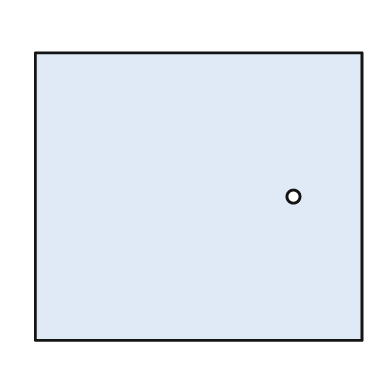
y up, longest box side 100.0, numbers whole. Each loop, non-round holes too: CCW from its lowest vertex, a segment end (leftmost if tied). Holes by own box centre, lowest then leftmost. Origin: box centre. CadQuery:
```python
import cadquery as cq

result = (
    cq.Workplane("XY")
    .moveTo(-50.0, -44.0)
    .lineTo(50.0, -44.0)
    .lineTo(50.0, 44.0)
    .lineTo(-50.0, 44.0)
    .close()
    .moveTo(29.0, 0.0)
    .circle(2.0)
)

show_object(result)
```